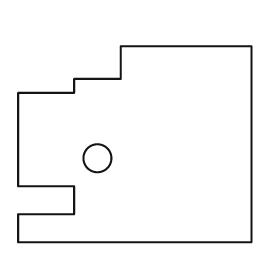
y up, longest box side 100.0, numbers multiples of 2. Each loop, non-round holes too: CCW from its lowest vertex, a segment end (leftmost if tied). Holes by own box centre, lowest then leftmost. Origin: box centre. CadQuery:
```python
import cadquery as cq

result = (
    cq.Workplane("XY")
    .moveTo(-50.0, -42.0)
    .lineTo(50.0, -42.0)
    .lineTo(50.0, 42.0)
    .lineTo(-6.0, 42.0)
    .lineTo(-6.0, 28.0)
    .lineTo(-26.0, 28.0)
    .lineTo(-26.0, 22.0)
    .lineTo(-50.0, 22.0)
    .lineTo(-50.0, -18.0)
    .lineTo(-26.0, -18.0)
    .lineTo(-26.0, -30.0)
    .lineTo(-50.0, -30.0)
    .close()
    .moveTo(-16.0, -6.0)
    .circle(6.0)
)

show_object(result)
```